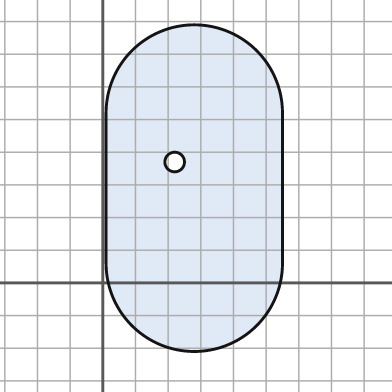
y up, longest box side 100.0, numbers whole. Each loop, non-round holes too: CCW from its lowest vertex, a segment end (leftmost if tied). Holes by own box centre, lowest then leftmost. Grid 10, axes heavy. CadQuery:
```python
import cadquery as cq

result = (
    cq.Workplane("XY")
    .moveTo(1.0, 6.0)
    .threePointArc((28.0, -21.0), (55.0, 6.0))
    .lineTo(55.0, 52.0)
    .threePointArc((28.0, 79.0), (1.0, 52.0))
    .close()
    .moveTo(22.0, 37.0)
    .circle(3.0)
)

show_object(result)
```